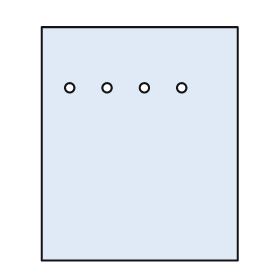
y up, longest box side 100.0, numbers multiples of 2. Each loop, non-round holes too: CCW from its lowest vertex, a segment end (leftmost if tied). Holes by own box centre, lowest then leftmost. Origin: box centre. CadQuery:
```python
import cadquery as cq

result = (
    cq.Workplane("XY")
    .moveTo(-42.0, -50.0)
    .lineTo(42.0, -50.0)
    .lineTo(42.0, 50.0)
    .lineTo(-42.0, 50.0)
    .close()
    .moveTo(-30.0, 24.0)
    .circle(2.0)
    .moveTo(-14.0, 24.0)
    .circle(2.0)
    .moveTo(2.0, 24.0)
    .circle(2.0)
    .moveTo(18.0, 24.0)
    .circle(2.0)
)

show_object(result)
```